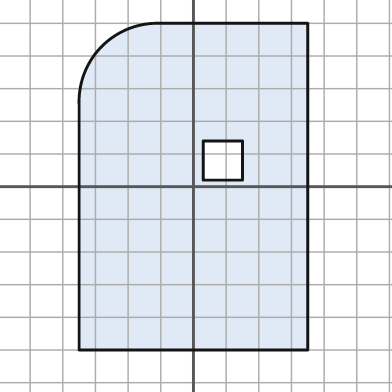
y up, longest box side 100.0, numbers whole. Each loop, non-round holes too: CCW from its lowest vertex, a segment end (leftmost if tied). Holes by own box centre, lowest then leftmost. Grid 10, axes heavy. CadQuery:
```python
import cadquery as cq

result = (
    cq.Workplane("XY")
    .moveTo(-35.0, -50.0)
    .lineTo(35.0, -50.0)
    .lineTo(35.0, 50.0)
    .lineTo(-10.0, 50.0)
    .threePointArc((-28.0, 43.0), (-35.0, 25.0))
    .close()
    .moveTo(3.0, 2.0)
    .lineTo(15.0, 2.0)
    .lineTo(15.0, 14.0)
    .lineTo(3.0, 14.0)
    .close()
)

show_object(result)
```